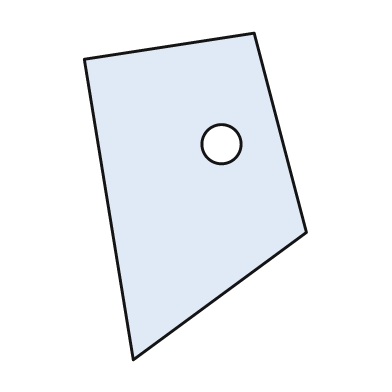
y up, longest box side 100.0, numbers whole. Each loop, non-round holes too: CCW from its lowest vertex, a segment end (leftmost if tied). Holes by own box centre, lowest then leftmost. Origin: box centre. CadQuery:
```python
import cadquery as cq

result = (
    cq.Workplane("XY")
    .moveTo(-19.0, -50.0)
    .lineTo(34.0, -11.0)
    .lineTo(18.0, 50.0)
    .lineTo(-34.0, 42.0)
    .close()
    .moveTo(8.0, 16.0)
    .circle(6.0)
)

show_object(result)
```